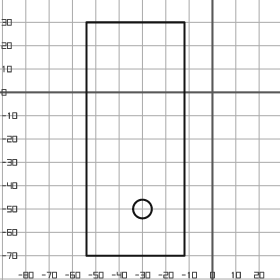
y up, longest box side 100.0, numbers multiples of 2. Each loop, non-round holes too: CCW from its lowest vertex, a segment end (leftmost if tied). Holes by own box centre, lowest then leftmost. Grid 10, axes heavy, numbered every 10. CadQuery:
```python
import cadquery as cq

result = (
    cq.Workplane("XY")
    .moveTo(-54.0, -70.0)
    .lineTo(-12.0, -70.0)
    .lineTo(-12.0, 30.0)
    .lineTo(-54.0, 30.0)
    .close()
    .moveTo(-30.0, -50.0)
    .circle(4.0)
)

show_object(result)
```